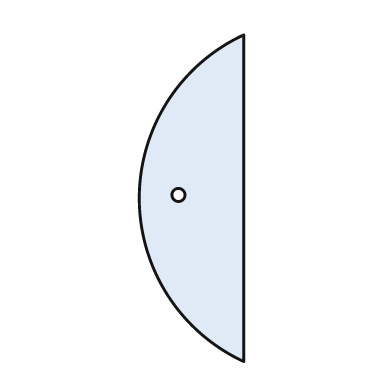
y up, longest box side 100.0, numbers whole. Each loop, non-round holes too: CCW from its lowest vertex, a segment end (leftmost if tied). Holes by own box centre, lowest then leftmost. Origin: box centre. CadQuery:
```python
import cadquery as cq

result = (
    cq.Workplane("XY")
    .moveTo(16.0, -50.0)
    .lineTo(16.0, 50.0)
    .threePointArc((-16.0, 0.0), (16.0, -50.0))
    .close()
    .moveTo(-4.0, 1.0)
    .circle(2.0)
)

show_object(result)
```